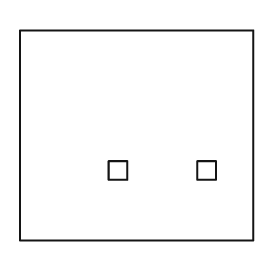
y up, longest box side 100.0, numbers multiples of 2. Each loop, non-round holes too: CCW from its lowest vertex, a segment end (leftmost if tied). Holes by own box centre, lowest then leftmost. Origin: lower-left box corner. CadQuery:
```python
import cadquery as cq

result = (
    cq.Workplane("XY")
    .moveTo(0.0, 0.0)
    .lineTo(100.0, 0.0)
    .lineTo(100.0, 90.0)
    .lineTo(0.0, 90.0)
    .close()
    .moveTo(38.0, 26.0)
    .lineTo(46.0, 26.0)
    .lineTo(46.0, 34.0)
    .lineTo(38.0, 34.0)
    .close()
    .moveTo(76.0, 26.0)
    .lineTo(84.0, 26.0)
    .lineTo(84.0, 34.0)
    .lineTo(76.0, 34.0)
    .close()
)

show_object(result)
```